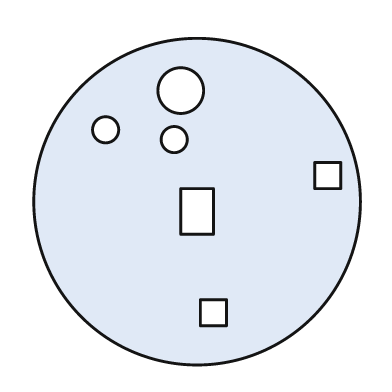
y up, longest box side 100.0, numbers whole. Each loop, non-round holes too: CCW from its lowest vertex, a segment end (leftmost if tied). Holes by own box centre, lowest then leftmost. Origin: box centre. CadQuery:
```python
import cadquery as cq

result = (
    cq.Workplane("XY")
    .moveTo(0.0, 0.0)
    .circle(50.0)
    .moveTo(1.0, -38.0)
    .lineTo(9.0, -38.0)
    .lineTo(9.0, -30.0)
    .lineTo(1.0, -30.0)
    .close()
    .moveTo(-5.0, -10.0)
    .lineTo(5.0, -10.0)
    .lineTo(5.0, 4.0)
    .lineTo(-5.0, 4.0)
    .close()
    .moveTo(36.0, 4.0)
    .lineTo(44.0, 4.0)
    .lineTo(44.0, 12.0)
    .lineTo(36.0, 12.0)
    .close()
    .moveTo(-7.0, 19.0)
    .circle(4.0)
    .moveTo(-28.0, 22.0)
    .circle(4.0)
    .moveTo(-5.0, 34.0)
    .circle(7.0)
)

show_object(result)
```